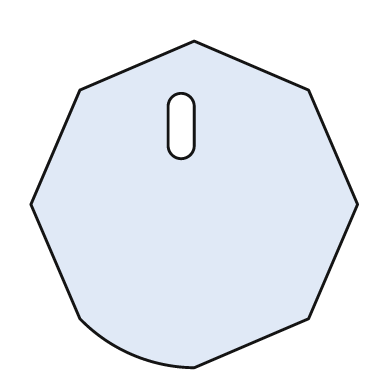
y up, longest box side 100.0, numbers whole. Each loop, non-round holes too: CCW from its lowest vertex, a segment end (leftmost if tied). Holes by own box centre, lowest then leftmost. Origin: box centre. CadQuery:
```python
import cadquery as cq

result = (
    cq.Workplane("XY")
    .moveTo(0.0, -50.0)
    .lineTo(35.0, -35.0)
    .lineTo(50.0, 0.0)
    .lineTo(35.0, 35.0)
    .lineTo(0.0, 50.0)
    .lineTo(-35.0, 35.0)
    .lineTo(-50.0, 0.0)
    .lineTo(-35.0, -35.0)
    .threePointArc((-19.0, -46.0), (0.0, -50.0))
    .close()
    .moveTo(-8.0, 18.0)
    .threePointArc((-4.0, 14.0), (0.0, 18.0))
    .lineTo(0.0, 30.0)
    .threePointArc((-4.0, 34.0), (-8.0, 30.0))
    .close()
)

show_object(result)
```